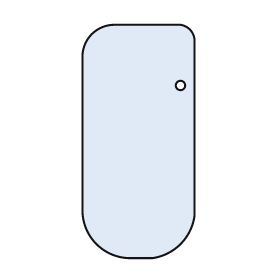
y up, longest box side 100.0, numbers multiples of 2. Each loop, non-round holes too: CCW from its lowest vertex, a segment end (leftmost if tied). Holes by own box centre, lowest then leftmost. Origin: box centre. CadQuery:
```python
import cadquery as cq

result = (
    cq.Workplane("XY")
    .moveTo(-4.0, -50.0)
    .lineTo(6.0, -50.0)
    .threePointArc((18.0, -44.0), (24.0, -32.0))
    .lineTo(24.0, 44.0)
    .threePointArc((22.0, 48.0), (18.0, 50.0))
    .lineTo(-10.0, 50.0)
    .threePointArc((-20.0, 46.0), (-24.0, 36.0))
    .lineTo(-24.0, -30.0)
    .threePointArc((-18.0, -44.0), (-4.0, -50.0))
    .close()
    .moveTo(18.0, 24.0)
    .circle(2.0)
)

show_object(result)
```